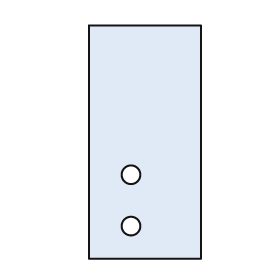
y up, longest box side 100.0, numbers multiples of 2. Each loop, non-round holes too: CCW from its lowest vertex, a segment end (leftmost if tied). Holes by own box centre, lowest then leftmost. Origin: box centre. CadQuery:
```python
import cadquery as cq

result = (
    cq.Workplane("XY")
    .moveTo(-24.0, -50.0)
    .lineTo(24.0, -50.0)
    .lineTo(24.0, 50.0)
    .lineTo(-24.0, 50.0)
    .close()
    .moveTo(-6.0, -36.0)
    .circle(4.0)
    .moveTo(-6.0, -14.0)
    .circle(4.0)
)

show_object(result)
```